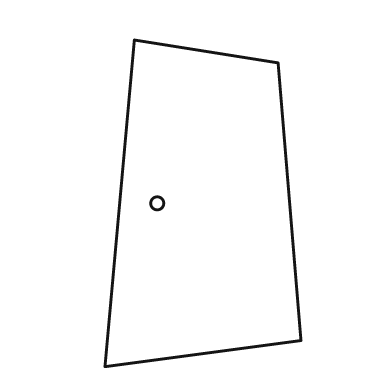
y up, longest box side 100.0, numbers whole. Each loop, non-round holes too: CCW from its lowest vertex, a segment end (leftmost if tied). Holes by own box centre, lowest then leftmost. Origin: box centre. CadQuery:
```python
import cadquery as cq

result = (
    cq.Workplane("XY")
    .moveTo(-30.0, -50.0)
    .lineTo(30.0, -42.0)
    .lineTo(23.0, 43.0)
    .lineTo(-21.0, 50.0)
    .close()
    .moveTo(-14.0, 0.0)
    .circle(2.0)
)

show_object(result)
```